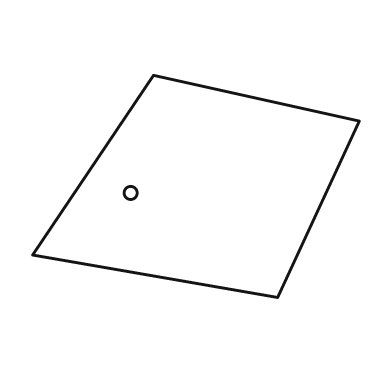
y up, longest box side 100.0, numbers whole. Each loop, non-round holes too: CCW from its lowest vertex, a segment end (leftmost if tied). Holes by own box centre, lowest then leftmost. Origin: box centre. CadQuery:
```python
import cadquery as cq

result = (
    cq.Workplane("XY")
    .moveTo(25.0, -34.0)
    .lineTo(50.0, 20.0)
    .lineTo(-13.0, 34.0)
    .lineTo(-50.0, -21.0)
    .close()
    .moveTo(-20.0, -2.0)
    .circle(2.0)
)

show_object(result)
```